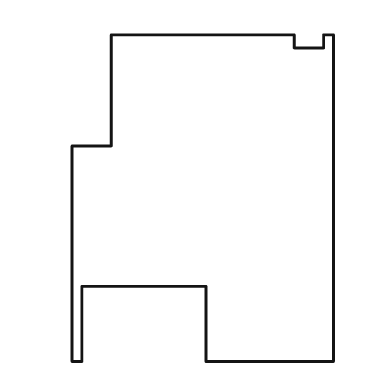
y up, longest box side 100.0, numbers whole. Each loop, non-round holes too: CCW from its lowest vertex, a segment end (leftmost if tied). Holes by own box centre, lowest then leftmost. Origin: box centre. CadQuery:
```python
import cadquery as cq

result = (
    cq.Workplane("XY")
    .moveTo(-40.0, -50.0)
    .lineTo(-37.0, -50.0)
    .lineTo(-37.0, -27.0)
    .lineTo(1.0, -27.0)
    .lineTo(1.0, -50.0)
    .lineTo(40.0, -50.0)
    .lineTo(40.0, 50.0)
    .lineTo(37.0, 50.0)
    .lineTo(37.0, 46.0)
    .lineTo(28.0, 46.0)
    .lineTo(28.0, 50.0)
    .lineTo(-28.0, 50.0)
    .lineTo(-28.0, 16.0)
    .lineTo(-40.0, 16.0)
    .close()
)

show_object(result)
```